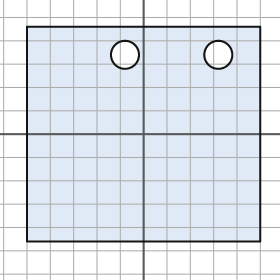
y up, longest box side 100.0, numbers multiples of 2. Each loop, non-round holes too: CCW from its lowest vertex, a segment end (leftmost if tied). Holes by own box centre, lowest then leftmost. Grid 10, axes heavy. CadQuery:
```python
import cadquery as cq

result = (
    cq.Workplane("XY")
    .moveTo(-50.0, -46.0)
    .lineTo(50.0, -46.0)
    .lineTo(50.0, 46.0)
    .lineTo(-50.0, 46.0)
    .close()
    .moveTo(-8.0, 34.0)
    .circle(6.0)
    .moveTo(32.0, 34.0)
    .circle(6.0)
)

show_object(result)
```